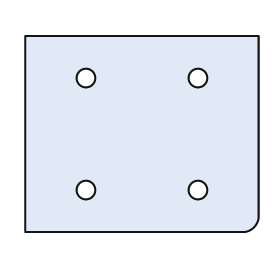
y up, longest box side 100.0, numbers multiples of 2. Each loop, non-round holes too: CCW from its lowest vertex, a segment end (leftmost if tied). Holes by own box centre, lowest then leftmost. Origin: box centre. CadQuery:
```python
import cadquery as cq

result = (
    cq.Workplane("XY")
    .moveTo(-50.0, -42.0)
    .lineTo(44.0, -42.0)
    .threePointArc((48.0, -40.0), (50.0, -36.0))
    .lineTo(50.0, 42.0)
    .lineTo(-50.0, 42.0)
    .close()
    .moveTo(-24.0, -24.0)
    .circle(4.0)
    .moveTo(24.0, -24.0)
    .circle(4.0)
    .moveTo(-24.0, 24.0)
    .circle(4.0)
    .moveTo(24.0, 24.0)
    .circle(4.0)
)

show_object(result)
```